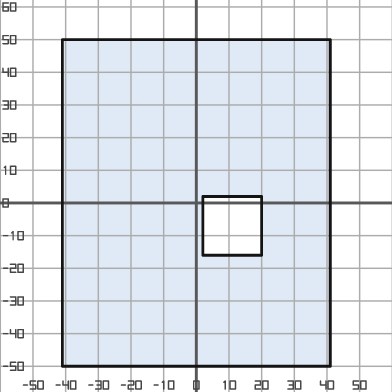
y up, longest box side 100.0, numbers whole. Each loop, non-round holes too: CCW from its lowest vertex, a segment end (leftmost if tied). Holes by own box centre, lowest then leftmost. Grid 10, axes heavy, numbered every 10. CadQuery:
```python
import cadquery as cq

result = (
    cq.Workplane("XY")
    .moveTo(-41.0, -50.0)
    .lineTo(41.0, -50.0)
    .lineTo(41.0, 50.0)
    .lineTo(-41.0, 50.0)
    .close()
    .moveTo(2.0, -16.0)
    .lineTo(20.0, -16.0)
    .lineTo(20.0, 2.0)
    .lineTo(2.0, 2.0)
    .close()
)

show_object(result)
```